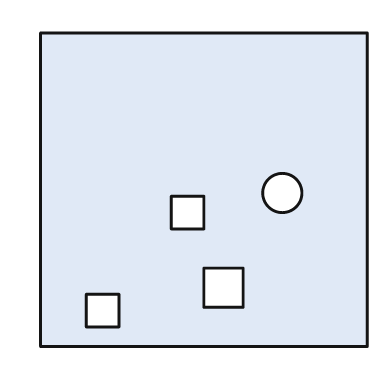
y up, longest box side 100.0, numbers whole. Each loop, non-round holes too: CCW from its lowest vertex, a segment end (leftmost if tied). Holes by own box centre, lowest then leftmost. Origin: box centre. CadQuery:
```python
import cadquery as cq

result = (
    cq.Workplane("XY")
    .moveTo(-50.0, -48.0)
    .lineTo(50.0, -48.0)
    .lineTo(50.0, 48.0)
    .lineTo(-50.0, 48.0)
    .close()
    .moveTo(-36.0, -42.0)
    .lineTo(-26.0, -42.0)
    .lineTo(-26.0, -32.0)
    .lineTo(-36.0, -32.0)
    .close()
    .moveTo(0.0, -36.0)
    .lineTo(12.0, -36.0)
    .lineTo(12.0, -24.0)
    .lineTo(0.0, -24.0)
    .close()
    .moveTo(-10.0, -12.0)
    .lineTo(0.0, -12.0)
    .lineTo(0.0, -2.0)
    .lineTo(-10.0, -2.0)
    .close()
    .moveTo(24.0, -1.0)
    .circle(6.0)
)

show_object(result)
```